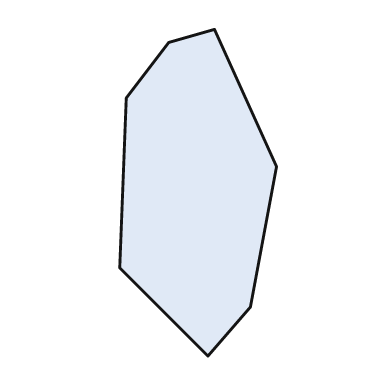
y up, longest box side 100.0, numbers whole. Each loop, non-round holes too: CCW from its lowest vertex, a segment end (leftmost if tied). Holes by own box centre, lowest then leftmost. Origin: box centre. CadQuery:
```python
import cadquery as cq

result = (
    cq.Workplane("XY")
    .moveTo(3.0, -50.0)
    .lineTo(16.0, -35.0)
    .lineTo(24.0, 8.0)
    .lineTo(5.0, 50.0)
    .lineTo(-9.0, 46.0)
    .lineTo(-22.0, 29.0)
    .lineTo(-24.0, -23.0)
    .close()
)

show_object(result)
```